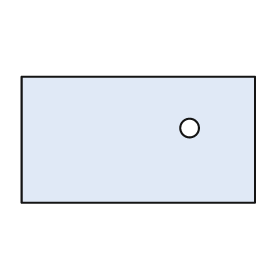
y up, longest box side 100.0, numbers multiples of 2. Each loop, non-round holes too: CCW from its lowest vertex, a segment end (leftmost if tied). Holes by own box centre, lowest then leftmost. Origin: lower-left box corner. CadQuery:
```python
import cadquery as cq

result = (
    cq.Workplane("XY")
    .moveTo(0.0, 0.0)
    .lineTo(100.0, 0.0)
    .lineTo(100.0, 54.0)
    .lineTo(0.0, 54.0)
    .close()
    .moveTo(72.0, 32.0)
    .circle(4.0)
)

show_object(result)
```